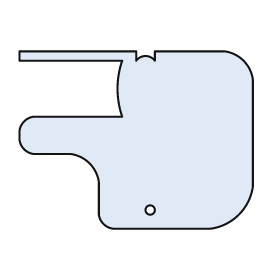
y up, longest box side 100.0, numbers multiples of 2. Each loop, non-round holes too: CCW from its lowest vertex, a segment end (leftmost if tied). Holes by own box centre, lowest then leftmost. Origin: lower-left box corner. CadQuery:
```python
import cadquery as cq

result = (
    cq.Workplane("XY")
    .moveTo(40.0, 0.0)
    .lineTo(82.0, 0.0)
    .threePointArc((94.0, 6.0), (100.0, 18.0))
    .lineTo(100.0, 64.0)
    .threePointArc((96.0, 72.0), (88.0, 76.0))
    .lineTo(58.0, 76.0)
    .lineTo(58.0, 72.0)
    .threePointArc((54.0, 74.0), (50.0, 72.0))
    .lineTo(50.0, 76.0)
    .lineTo(0.0, 76.0)
    .lineTo(0.0, 72.0)
    .lineTo(44.0, 72.0)
    .threePointArc((42.0, 60.0), (44.0, 48.0))
    .lineTo(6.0, 48.0)
    .threePointArc((2.0, 46.0), (0.0, 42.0))
    .lineTo(0.0, 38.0)
    .threePointArc((2.0, 34.0), (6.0, 32.0))
    .lineTo(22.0, 32.0)
    .threePointArc((30.0, 28.0), (34.0, 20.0))
    .lineTo(34.0, 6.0)
    .threePointArc((36.0, 2.0), (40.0, 0.0))
    .close()
    .moveTo(56.0, 8.0)
    .circle(2.0)
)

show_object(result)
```